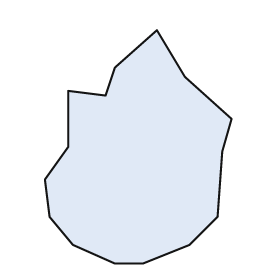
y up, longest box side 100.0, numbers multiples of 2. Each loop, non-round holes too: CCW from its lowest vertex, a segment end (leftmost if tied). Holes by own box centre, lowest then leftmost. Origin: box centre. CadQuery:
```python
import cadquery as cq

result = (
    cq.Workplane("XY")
    .moveTo(-10.0, -50.0)
    .lineTo(2.0, -50.0)
    .lineTo(22.0, -42.0)
    .lineTo(34.0, -30.0)
    .lineTo(36.0, -2.0)
    .lineTo(40.0, 12.0)
    .lineTo(20.0, 30.0)
    .lineTo(8.0, 50.0)
    .lineTo(-10.0, 34.0)
    .lineTo(-14.0, 22.0)
    .lineTo(-30.0, 24.0)
    .lineTo(-30.0, 0.0)
    .lineTo(-40.0, -14.0)
    .lineTo(-38.0, -30.0)
    .lineTo(-28.0, -42.0)
    .close()
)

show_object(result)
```